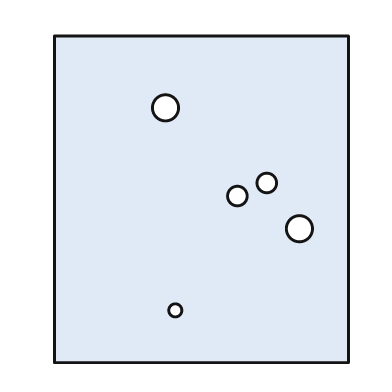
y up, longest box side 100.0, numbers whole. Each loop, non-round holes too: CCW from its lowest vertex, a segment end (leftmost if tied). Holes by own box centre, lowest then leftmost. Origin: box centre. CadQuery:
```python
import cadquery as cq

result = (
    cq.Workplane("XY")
    .moveTo(-45.0, -50.0)
    .lineTo(45.0, -50.0)
    .lineTo(45.0, 50.0)
    .lineTo(-45.0, 50.0)
    .close()
    .moveTo(-8.0, -34.0)
    .circle(2.0)
    .moveTo(30.0, -9.0)
    .circle(4.0)
    .moveTo(11.0, 1.0)
    .circle(3.0)
    .moveTo(20.0, 5.0)
    .circle(3.0)
    .moveTo(-11.0, 28.0)
    .circle(4.0)
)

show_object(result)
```